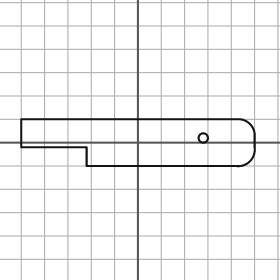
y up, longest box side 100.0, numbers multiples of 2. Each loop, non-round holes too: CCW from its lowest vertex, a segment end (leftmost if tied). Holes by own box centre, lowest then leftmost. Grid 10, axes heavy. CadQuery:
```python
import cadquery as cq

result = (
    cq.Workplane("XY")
    .moveTo(-22.0, -10.0)
    .lineTo(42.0, -10.0)
    .threePointArc((48.0, -8.0), (50.0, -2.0))
    .lineTo(50.0, 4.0)
    .threePointArc((48.0, 8.0), (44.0, 10.0))
    .lineTo(-50.0, 10.0)
    .lineTo(-50.0, -2.0)
    .lineTo(-22.0, -2.0)
    .close()
    .moveTo(28.0, 2.0)
    .circle(2.0)
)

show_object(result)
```